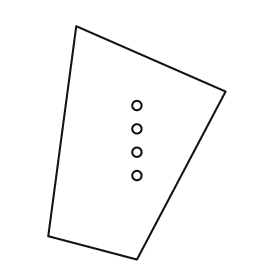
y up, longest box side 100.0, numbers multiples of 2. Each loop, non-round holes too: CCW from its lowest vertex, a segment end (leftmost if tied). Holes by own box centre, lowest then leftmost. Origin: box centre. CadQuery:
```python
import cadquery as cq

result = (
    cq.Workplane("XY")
    .moveTo(0.0, -50.0)
    .lineTo(38.0, 22.0)
    .lineTo(-26.0, 50.0)
    .lineTo(-38.0, -40.0)
    .close()
    .moveTo(0.0, -14.0)
    .circle(2.0)
    .moveTo(0.0, -4.0)
    .circle(2.0)
    .moveTo(0.0, 6.0)
    .circle(2.0)
    .moveTo(0.0, 16.0)
    .circle(2.0)
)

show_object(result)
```